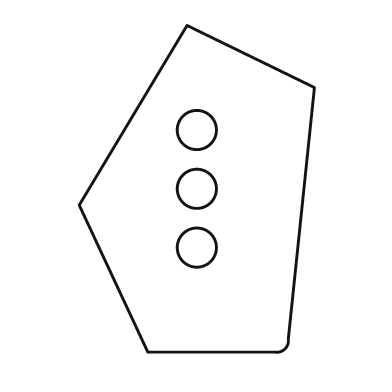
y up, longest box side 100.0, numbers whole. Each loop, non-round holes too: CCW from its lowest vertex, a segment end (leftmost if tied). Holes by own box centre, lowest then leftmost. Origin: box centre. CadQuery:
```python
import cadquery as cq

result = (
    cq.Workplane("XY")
    .moveTo(-15.0, -50.0)
    .lineTo(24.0, -50.0)
    .threePointArc((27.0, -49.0), (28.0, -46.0))
    .lineTo(36.0, 31.0)
    .lineTo(-3.0, 50.0)
    .lineTo(-36.0, -5.0)
    .close()
    .moveTo(0.0, -18.0)
    .circle(6.0)
    .moveTo(0.0, 0.0)
    .circle(6.0)
    .moveTo(0.0, 18.0)
    .circle(6.0)
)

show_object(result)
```